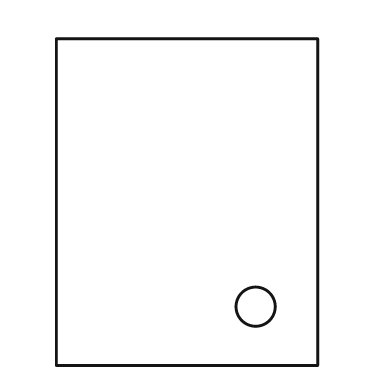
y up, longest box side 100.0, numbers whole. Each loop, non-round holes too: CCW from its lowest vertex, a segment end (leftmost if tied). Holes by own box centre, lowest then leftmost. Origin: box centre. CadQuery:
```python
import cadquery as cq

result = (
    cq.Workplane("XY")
    .moveTo(-40.0, -50.0)
    .lineTo(40.0, -50.0)
    .lineTo(40.0, 50.0)
    .lineTo(-40.0, 50.0)
    .close()
    .moveTo(21.0, -32.0)
    .circle(6.0)
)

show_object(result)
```